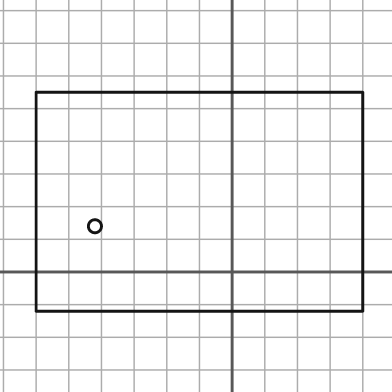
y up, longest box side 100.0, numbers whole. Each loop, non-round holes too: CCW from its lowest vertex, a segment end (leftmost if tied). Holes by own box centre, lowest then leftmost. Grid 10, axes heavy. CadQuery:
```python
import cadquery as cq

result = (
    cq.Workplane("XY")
    .moveTo(-60.0, -12.0)
    .lineTo(40.0, -12.0)
    .lineTo(40.0, 55.0)
    .lineTo(-60.0, 55.0)
    .close()
    .moveTo(-42.0, 14.0)
    .circle(2.0)
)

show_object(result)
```